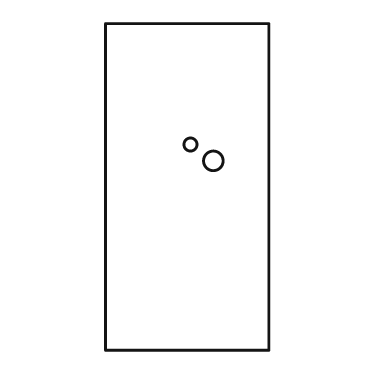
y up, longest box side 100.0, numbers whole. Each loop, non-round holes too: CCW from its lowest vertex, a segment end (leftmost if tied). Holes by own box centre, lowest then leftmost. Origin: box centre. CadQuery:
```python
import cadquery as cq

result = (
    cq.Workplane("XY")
    .moveTo(-25.0, -50.0)
    .lineTo(25.0, -50.0)
    .lineTo(25.0, 50.0)
    .lineTo(-25.0, 50.0)
    .close()
    .moveTo(8.0, 8.0)
    .circle(3.0)
    .moveTo(1.0, 13.0)
    .circle(2.0)
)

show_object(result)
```